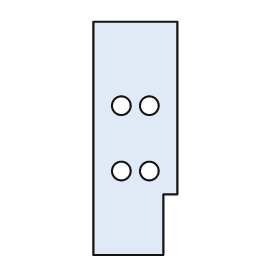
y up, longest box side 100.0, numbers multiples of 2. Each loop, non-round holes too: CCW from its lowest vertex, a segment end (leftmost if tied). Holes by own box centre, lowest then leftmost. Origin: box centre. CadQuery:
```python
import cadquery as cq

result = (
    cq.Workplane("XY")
    .moveTo(-18.0, -50.0)
    .lineTo(12.0, -50.0)
    .lineTo(12.0, -24.0)
    .lineTo(18.0, -24.0)
    .lineTo(18.0, 50.0)
    .lineTo(-18.0, 50.0)
    .close()
    .moveTo(-6.0, -14.0)
    .circle(4.0)
    .moveTo(6.0, -14.0)
    .circle(4.0)
    .moveTo(-6.0, 14.0)
    .circle(4.0)
    .moveTo(6.0, 14.0)
    .circle(4.0)
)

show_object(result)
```